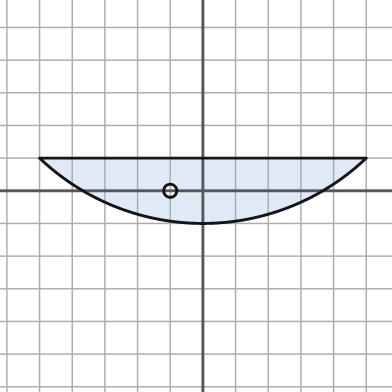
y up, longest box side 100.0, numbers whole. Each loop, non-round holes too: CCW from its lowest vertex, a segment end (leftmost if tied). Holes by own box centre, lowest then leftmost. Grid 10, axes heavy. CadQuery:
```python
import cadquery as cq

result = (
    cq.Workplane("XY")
    .moveTo(-50.0, 10.0)
    .threePointArc((0.0, -10.0), (50.0, 10.0))
    .close()
    .moveTo(-10.0, 0.0)
    .circle(2.0)
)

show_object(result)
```